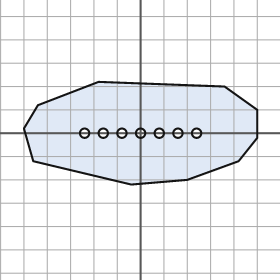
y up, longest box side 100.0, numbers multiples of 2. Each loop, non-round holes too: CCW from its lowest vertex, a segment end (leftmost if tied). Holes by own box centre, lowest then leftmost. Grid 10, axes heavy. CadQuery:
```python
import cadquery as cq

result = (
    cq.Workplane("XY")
    .moveTo(-4.0, -22.0)
    .lineTo(20.0, -20.0)
    .lineTo(42.0, -12.0)
    .lineTo(50.0, -2.0)
    .lineTo(50.0, 10.0)
    .lineTo(36.0, 20.0)
    .lineTo(-18.0, 22.0)
    .lineTo(-44.0, 12.0)
    .lineTo(-50.0, 2.0)
    .lineTo(-46.0, -12.0)
    .close()
    .moveTo(-24.0, 0.0)
    .circle(2.0)
    .moveTo(-16.0, 0.0)
    .circle(2.0)
    .moveTo(-8.0, 0.0)
    .circle(2.0)
    .moveTo(0.0, 0.0)
    .circle(2.0)
    .moveTo(8.0, 0.0)
    .circle(2.0)
    .moveTo(16.0, 0.0)
    .circle(2.0)
    .moveTo(24.0, 0.0)
    .circle(2.0)
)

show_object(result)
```